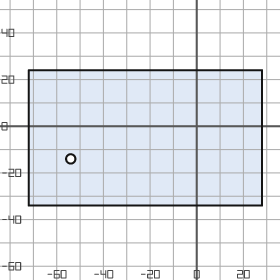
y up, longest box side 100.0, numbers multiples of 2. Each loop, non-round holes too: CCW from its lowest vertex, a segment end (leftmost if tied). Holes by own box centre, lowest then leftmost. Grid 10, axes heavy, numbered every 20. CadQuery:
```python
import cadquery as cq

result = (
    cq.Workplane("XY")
    .moveTo(-72.0, -34.0)
    .lineTo(28.0, -34.0)
    .lineTo(28.0, 24.0)
    .lineTo(-72.0, 24.0)
    .close()
    .moveTo(-54.0, -14.0)
    .circle(2.0)
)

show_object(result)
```